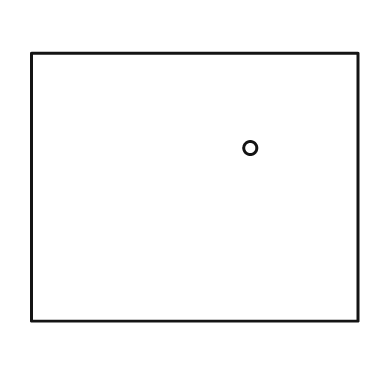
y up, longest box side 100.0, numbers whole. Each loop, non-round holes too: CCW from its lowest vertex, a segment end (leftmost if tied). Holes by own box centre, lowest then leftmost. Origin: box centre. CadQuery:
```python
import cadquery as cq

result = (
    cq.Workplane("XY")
    .moveTo(-50.0, -41.0)
    .lineTo(50.0, -41.0)
    .lineTo(50.0, 41.0)
    .lineTo(-50.0, 41.0)
    .close()
    .moveTo(17.0, 12.0)
    .circle(2.0)
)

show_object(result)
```